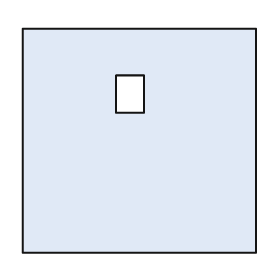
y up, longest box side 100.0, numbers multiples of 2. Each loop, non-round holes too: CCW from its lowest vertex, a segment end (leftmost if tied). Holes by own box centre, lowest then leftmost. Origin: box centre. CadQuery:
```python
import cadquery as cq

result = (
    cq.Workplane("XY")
    .moveTo(-50.0, -48.0)
    .lineTo(50.0, -48.0)
    .lineTo(50.0, 48.0)
    .lineTo(-50.0, 48.0)
    .close()
    .moveTo(-10.0, 12.0)
    .lineTo(2.0, 12.0)
    .lineTo(2.0, 28.0)
    .lineTo(-10.0, 28.0)
    .close()
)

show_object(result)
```